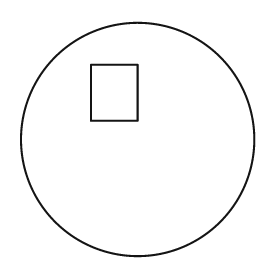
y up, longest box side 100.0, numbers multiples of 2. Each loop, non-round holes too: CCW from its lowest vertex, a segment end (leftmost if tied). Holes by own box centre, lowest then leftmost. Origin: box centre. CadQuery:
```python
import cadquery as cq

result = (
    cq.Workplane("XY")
    .moveTo(0.0, 0.0)
    .circle(50.0)
    .moveTo(-20.0, 8.0)
    .lineTo(0.0, 8.0)
    .lineTo(0.0, 32.0)
    .lineTo(-20.0, 32.0)
    .close()
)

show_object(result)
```